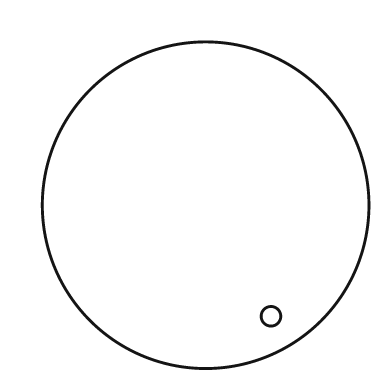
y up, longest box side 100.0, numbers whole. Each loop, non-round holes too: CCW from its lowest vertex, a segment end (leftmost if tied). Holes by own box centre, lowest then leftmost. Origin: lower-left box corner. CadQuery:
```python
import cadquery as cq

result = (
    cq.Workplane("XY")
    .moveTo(50.0, 50.0)
    .circle(50.0)
    .moveTo(70.0, 16.0)
    .circle(3.0)
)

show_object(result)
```